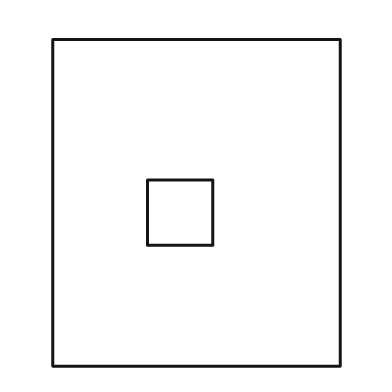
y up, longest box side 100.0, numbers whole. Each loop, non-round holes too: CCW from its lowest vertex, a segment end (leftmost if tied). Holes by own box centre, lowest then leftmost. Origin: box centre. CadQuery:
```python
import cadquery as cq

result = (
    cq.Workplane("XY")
    .moveTo(-44.0, -50.0)
    .lineTo(44.0, -50.0)
    .lineTo(44.0, 50.0)
    .lineTo(-44.0, 50.0)
    .close()
    .moveTo(-15.0, -13.0)
    .lineTo(5.0, -13.0)
    .lineTo(5.0, 7.0)
    .lineTo(-15.0, 7.0)
    .close()
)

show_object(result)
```